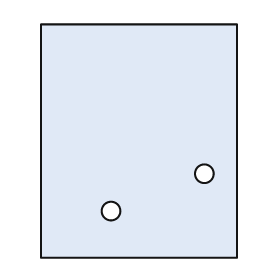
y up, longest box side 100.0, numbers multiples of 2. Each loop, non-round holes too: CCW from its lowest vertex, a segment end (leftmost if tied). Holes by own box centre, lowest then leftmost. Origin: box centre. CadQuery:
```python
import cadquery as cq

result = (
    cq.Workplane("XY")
    .moveTo(-42.0, -50.0)
    .lineTo(42.0, -50.0)
    .lineTo(42.0, 50.0)
    .lineTo(-42.0, 50.0)
    .close()
    .moveTo(-12.0, -30.0)
    .circle(4.0)
    .moveTo(28.0, -14.0)
    .circle(4.0)
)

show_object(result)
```